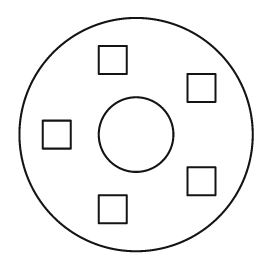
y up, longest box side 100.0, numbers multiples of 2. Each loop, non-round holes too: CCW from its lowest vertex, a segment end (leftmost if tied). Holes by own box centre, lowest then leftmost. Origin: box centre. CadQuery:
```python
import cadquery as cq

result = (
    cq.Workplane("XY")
    .moveTo(0.0, 0.0)
    .circle(50.0)
    .moveTo(-16.0, -38.0)
    .lineTo(-4.0, -38.0)
    .lineTo(-4.0, -26.0)
    .lineTo(-16.0, -26.0)
    .close()
    .moveTo(22.0, -26.0)
    .lineTo(34.0, -26.0)
    .lineTo(34.0, -14.0)
    .lineTo(22.0, -14.0)
    .close()
    .moveTo(-40.0, -6.0)
    .lineTo(-28.0, -6.0)
    .lineTo(-28.0, 6.0)
    .lineTo(-40.0, 6.0)
    .close()
    .moveTo(0.0, 0.0)
    .circle(16.0)
    .moveTo(22.0, 14.0)
    .lineTo(34.0, 14.0)
    .lineTo(34.0, 26.0)
    .lineTo(22.0, 26.0)
    .close()
    .moveTo(-16.0, 26.0)
    .lineTo(-4.0, 26.0)
    .lineTo(-4.0, 38.0)
    .lineTo(-16.0, 38.0)
    .close()
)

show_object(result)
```